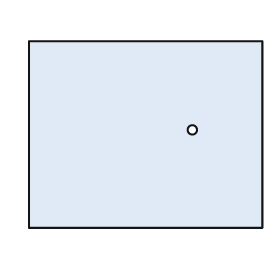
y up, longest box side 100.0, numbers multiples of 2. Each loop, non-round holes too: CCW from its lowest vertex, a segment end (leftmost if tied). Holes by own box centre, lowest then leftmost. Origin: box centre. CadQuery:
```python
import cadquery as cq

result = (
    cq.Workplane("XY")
    .moveTo(-50.0, -40.0)
    .lineTo(50.0, -40.0)
    .lineTo(50.0, 40.0)
    .lineTo(-50.0, 40.0)
    .close()
    .moveTo(20.0, 2.0)
    .circle(2.0)
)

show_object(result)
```